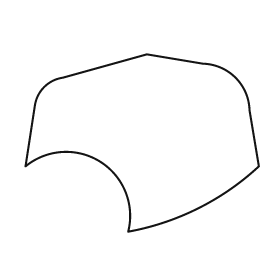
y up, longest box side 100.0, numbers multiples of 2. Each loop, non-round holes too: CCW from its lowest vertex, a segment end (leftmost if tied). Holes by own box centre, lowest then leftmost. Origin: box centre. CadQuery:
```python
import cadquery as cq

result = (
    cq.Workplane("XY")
    .moveTo(-6.0, -38.0)
    .threePointArc((24.0, -28.0), (50.0, -10.0))
    .lineTo(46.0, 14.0)
    .threePointArc((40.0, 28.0), (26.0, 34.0))
    .lineTo(2.0, 38.0)
    .lineTo(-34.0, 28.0)
    .threePointArc((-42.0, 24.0), (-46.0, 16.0))
    .lineTo(-50.0, -10.0)
    .threePointArc((-18.0, -8.0), (-6.0, -38.0))
    .close()
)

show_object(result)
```